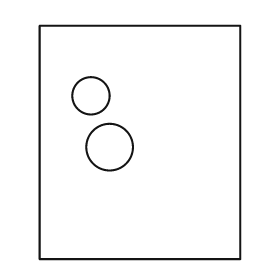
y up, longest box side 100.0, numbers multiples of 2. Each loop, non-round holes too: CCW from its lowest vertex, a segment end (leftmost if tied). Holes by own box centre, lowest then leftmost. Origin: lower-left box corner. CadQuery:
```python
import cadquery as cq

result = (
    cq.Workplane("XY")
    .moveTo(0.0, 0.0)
    .lineTo(86.0, 0.0)
    .lineTo(86.0, 100.0)
    .lineTo(0.0, 100.0)
    .close()
    .moveTo(30.0, 48.0)
    .circle(10.0)
    .moveTo(22.0, 70.0)
    .circle(8.0)
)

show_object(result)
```